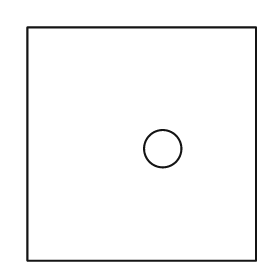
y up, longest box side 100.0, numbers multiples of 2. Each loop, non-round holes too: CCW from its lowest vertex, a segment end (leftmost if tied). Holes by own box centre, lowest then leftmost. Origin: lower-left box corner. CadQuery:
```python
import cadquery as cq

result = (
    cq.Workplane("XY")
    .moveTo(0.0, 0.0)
    .lineTo(98.0, 0.0)
    .lineTo(98.0, 100.0)
    .lineTo(0.0, 100.0)
    .close()
    .moveTo(58.0, 48.0)
    .circle(8.0)
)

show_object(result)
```